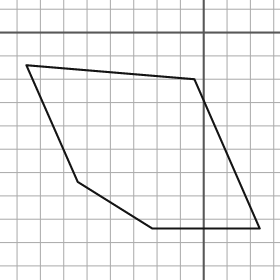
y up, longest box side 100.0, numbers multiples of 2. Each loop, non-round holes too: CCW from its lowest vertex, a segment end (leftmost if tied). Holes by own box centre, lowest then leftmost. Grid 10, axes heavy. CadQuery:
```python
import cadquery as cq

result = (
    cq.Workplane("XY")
    .moveTo(-22.0, -84.0)
    .lineTo(24.0, -84.0)
    .lineTo(-4.0, -20.0)
    .lineTo(-76.0, -14.0)
    .lineTo(-54.0, -64.0)
    .close()
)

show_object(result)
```